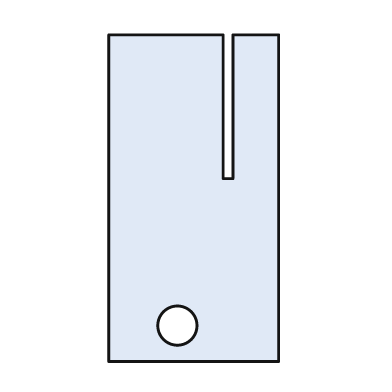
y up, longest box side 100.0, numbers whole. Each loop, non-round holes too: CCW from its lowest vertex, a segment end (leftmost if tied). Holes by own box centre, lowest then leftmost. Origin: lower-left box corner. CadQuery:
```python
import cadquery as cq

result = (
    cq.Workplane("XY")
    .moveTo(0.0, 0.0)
    .lineTo(52.0, 0.0)
    .lineTo(52.0, 100.0)
    .lineTo(38.0, 100.0)
    .lineTo(38.0, 56.0)
    .lineTo(35.0, 56.0)
    .lineTo(35.0, 100.0)
    .lineTo(0.0, 100.0)
    .close()
    .moveTo(21.0, 11.0)
    .circle(6.0)
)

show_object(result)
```